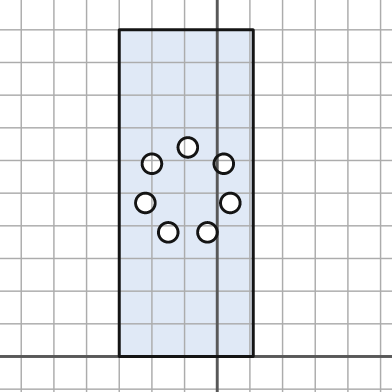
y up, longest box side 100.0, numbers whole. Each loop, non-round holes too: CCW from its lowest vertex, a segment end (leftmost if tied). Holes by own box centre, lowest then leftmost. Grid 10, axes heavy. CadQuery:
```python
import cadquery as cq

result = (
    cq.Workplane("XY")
    .moveTo(-30.0, 0.0)
    .lineTo(11.0, 0.0)
    .lineTo(11.0, 100.0)
    .lineTo(-30.0, 100.0)
    .close()
    .moveTo(-15.0, 38.0)
    .circle(3.0)
    .moveTo(-3.0, 38.0)
    .circle(3.0)
    .moveTo(-22.0, 47.0)
    .circle(3.0)
    .moveTo(4.0, 47.0)
    .circle(3.0)
    .moveTo(-20.0, 59.0)
    .circle(3.0)
    .moveTo(2.0, 59.0)
    .circle(3.0)
    .moveTo(-9.0, 64.0)
    .circle(3.0)
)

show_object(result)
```